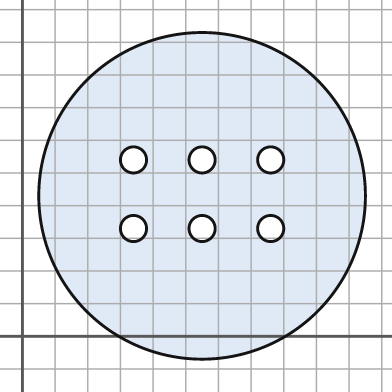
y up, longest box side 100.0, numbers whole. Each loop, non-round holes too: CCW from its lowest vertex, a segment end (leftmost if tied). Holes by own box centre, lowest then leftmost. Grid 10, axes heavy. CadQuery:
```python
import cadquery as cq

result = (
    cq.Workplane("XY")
    .moveTo(55.0, 43.0)
    .circle(50.0)
    .moveTo(34.0, 33.0)
    .circle(4.0)
    .moveTo(55.0, 33.0)
    .circle(4.0)
    .moveTo(76.0, 33.0)
    .circle(4.0)
    .moveTo(34.0, 54.0)
    .circle(4.0)
    .moveTo(55.0, 54.0)
    .circle(4.0)
    .moveTo(76.0, 54.0)
    .circle(4.0)
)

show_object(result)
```